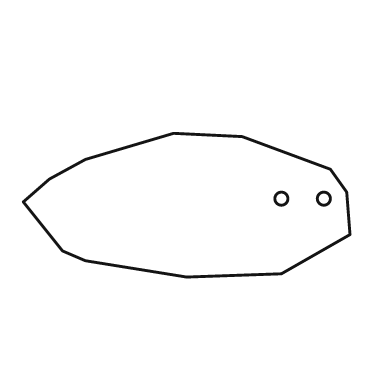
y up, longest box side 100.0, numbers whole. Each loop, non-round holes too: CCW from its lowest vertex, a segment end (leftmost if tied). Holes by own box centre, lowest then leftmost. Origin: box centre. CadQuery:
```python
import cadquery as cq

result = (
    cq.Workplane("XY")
    .moveTo(0.0, -22.0)
    .lineTo(29.0, -21.0)
    .lineTo(50.0, -9.0)
    .lineTo(49.0, 4.0)
    .lineTo(44.0, 11.0)
    .lineTo(17.0, 21.0)
    .lineTo(-4.0, 22.0)
    .lineTo(-31.0, 14.0)
    .lineTo(-42.0, 8.0)
    .lineTo(-50.0, 1.0)
    .lineTo(-38.0, -14.0)
    .lineTo(-31.0, -17.0)
    .close()
    .moveTo(29.0, 2.0)
    .circle(2.0)
    .moveTo(42.0, 2.0)
    .circle(2.0)
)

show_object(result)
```